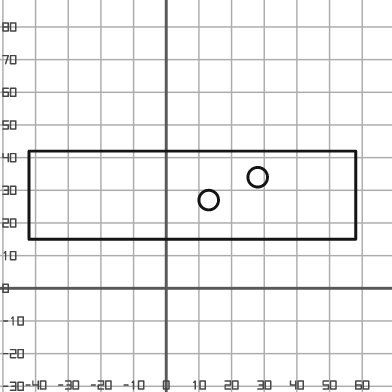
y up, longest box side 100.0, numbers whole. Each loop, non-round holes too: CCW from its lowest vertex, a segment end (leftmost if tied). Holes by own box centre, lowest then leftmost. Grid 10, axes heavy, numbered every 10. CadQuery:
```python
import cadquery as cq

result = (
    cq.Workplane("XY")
    .moveTo(-42.0, 15.0)
    .lineTo(58.0, 15.0)
    .lineTo(58.0, 42.0)
    .lineTo(-42.0, 42.0)
    .close()
    .moveTo(13.0, 27.0)
    .circle(3.0)
    .moveTo(28.0, 34.0)
    .circle(3.0)
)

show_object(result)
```